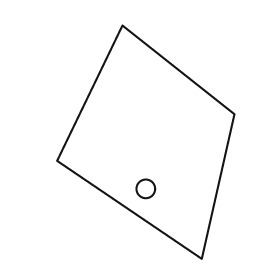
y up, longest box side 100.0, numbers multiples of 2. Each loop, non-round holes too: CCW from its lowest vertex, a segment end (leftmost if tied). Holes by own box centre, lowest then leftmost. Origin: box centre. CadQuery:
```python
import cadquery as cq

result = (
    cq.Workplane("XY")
    .moveTo(24.0, -50.0)
    .lineTo(38.0, 12.0)
    .lineTo(-10.0, 50.0)
    .lineTo(-38.0, -8.0)
    .close()
    .moveTo(0.0, -20.0)
    .circle(4.0)
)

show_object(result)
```